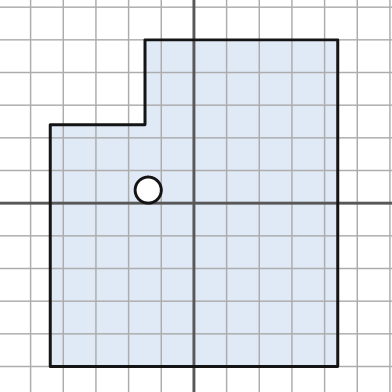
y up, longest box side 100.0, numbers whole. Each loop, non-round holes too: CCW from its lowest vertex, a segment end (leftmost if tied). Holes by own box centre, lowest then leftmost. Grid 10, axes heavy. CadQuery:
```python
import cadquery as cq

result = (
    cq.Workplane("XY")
    .moveTo(-44.0, -50.0)
    .lineTo(44.0, -50.0)
    .lineTo(44.0, 50.0)
    .lineTo(-15.0, 50.0)
    .lineTo(-15.0, 24.0)
    .lineTo(-44.0, 24.0)
    .close()
    .moveTo(-14.0, 4.0)
    .circle(4.0)
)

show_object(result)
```